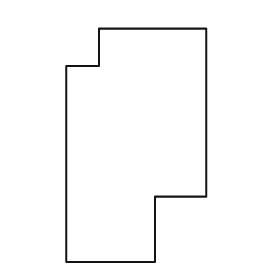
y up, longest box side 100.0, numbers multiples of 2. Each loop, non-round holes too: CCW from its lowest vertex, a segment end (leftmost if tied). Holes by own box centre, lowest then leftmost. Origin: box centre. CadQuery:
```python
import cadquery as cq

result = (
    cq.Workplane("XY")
    .moveTo(-30.0, -50.0)
    .lineTo(8.0, -50.0)
    .lineTo(8.0, -22.0)
    .lineTo(30.0, -22.0)
    .lineTo(30.0, 50.0)
    .lineTo(-16.0, 50.0)
    .lineTo(-16.0, 34.0)
    .lineTo(-30.0, 34.0)
    .close()
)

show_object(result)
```